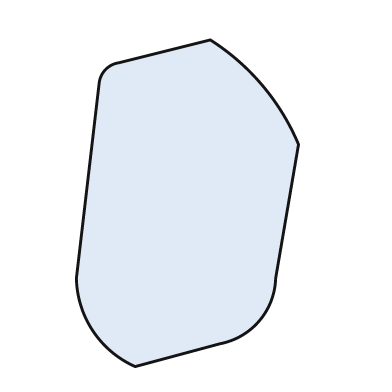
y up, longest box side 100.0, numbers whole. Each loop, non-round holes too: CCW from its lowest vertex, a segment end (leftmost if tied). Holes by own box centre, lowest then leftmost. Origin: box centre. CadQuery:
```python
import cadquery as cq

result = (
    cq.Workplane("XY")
    .moveTo(-16.0, -50.0)
    .lineTo(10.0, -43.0)
    .threePointArc((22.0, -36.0), (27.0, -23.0))
    .lineTo(34.0, 18.0)
    .threePointArc((23.0, 36.0), (7.0, 50.0))
    .lineTo(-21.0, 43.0)
    .threePointArc((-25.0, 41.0), (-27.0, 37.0))
    .lineTo(-34.0, -23.0)
    .threePointArc((-29.0, -39.0), (-16.0, -50.0))
    .close()
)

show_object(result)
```